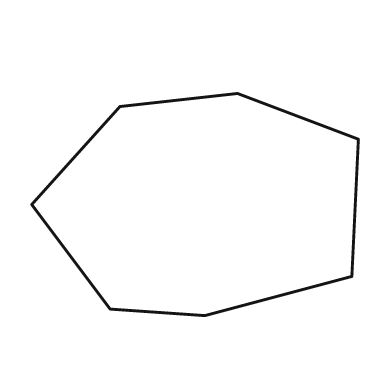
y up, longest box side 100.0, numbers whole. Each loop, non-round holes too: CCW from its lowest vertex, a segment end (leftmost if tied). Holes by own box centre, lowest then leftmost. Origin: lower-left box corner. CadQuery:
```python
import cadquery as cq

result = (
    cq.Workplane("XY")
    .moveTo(53.0, 0.0)
    .lineTo(98.0, 12.0)
    .lineTo(100.0, 54.0)
    .lineTo(63.0, 68.0)
    .lineTo(27.0, 64.0)
    .lineTo(0.0, 34.0)
    .lineTo(24.0, 2.0)
    .close()
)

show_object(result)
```